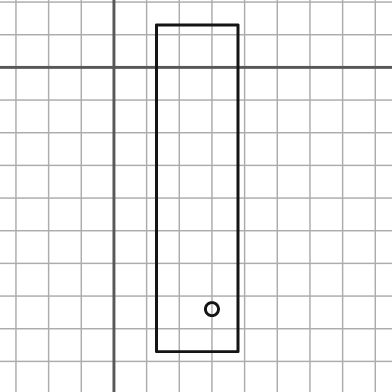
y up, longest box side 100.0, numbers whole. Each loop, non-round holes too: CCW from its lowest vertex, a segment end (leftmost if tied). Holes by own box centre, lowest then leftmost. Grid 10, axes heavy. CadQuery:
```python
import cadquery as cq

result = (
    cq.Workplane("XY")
    .moveTo(13.0, -87.0)
    .lineTo(38.0, -87.0)
    .lineTo(38.0, 13.0)
    .lineTo(13.0, 13.0)
    .close()
    .moveTo(30.0, -74.0)
    .circle(2.0)
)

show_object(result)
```